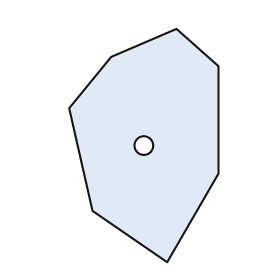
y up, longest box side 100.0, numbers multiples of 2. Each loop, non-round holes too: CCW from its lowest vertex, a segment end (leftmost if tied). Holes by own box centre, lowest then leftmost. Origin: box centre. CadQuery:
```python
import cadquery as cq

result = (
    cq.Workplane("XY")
    .moveTo(10.0, -50.0)
    .lineTo(32.0, -12.0)
    .lineTo(32.0, 34.0)
    .lineTo(14.0, 50.0)
    .lineTo(-14.0, 38.0)
    .lineTo(-32.0, 16.0)
    .lineTo(-22.0, -28.0)
    .close()
    .moveTo(0.0, 0.0)
    .circle(4.0)
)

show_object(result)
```